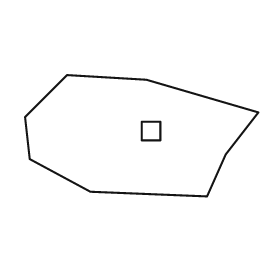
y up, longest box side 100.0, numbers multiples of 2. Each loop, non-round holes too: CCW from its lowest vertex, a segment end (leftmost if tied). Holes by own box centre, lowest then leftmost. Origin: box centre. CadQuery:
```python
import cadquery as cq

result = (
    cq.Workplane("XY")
    .moveTo(28.0, -26.0)
    .lineTo(36.0, -8.0)
    .lineTo(50.0, 10.0)
    .lineTo(2.0, 24.0)
    .lineTo(-32.0, 26.0)
    .lineTo(-50.0, 8.0)
    .lineTo(-48.0, -10.0)
    .lineTo(-22.0, -24.0)
    .close()
    .moveTo(0.0, -2.0)
    .lineTo(8.0, -2.0)
    .lineTo(8.0, 6.0)
    .lineTo(0.0, 6.0)
    .close()
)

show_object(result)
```